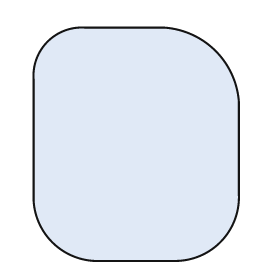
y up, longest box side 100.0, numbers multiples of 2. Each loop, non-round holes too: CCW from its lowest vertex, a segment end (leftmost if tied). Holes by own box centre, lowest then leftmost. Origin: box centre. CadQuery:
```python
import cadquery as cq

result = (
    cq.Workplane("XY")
    .moveTo(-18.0, -50.0)
    .lineTo(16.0, -50.0)
    .threePointArc((36.0, -42.0), (44.0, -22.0))
    .lineTo(44.0, 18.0)
    .threePointArc((34.0, 40.0), (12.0, 50.0))
    .lineTo(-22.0, 50.0)
    .threePointArc((-38.0, 44.0), (-44.0, 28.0))
    .lineTo(-44.0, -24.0)
    .threePointArc((-36.0, -42.0), (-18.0, -50.0))
    .close()
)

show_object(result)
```